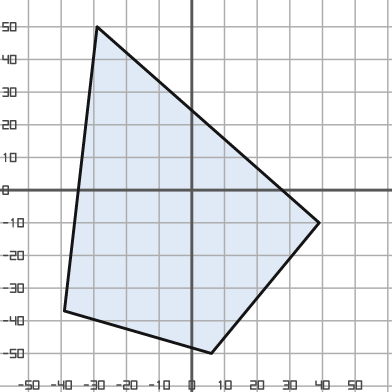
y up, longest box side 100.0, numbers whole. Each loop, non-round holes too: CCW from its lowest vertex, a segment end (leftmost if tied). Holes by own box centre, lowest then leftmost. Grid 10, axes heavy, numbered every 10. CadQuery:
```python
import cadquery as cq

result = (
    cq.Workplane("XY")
    .moveTo(6.0, -50.0)
    .lineTo(39.0, -10.0)
    .lineTo(-29.0, 50.0)
    .lineTo(-39.0, -37.0)
    .close()
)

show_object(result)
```